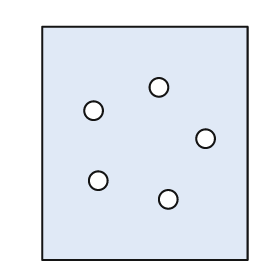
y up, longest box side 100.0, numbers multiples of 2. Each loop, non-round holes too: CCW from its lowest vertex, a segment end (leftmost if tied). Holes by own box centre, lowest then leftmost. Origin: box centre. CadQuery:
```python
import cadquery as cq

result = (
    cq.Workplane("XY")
    .moveTo(-44.0, -50.0)
    .lineTo(44.0, -50.0)
    .lineTo(44.0, 50.0)
    .lineTo(-44.0, 50.0)
    .close()
    .moveTo(10.0, -24.0)
    .circle(4.0)
    .moveTo(-20.0, -16.0)
    .circle(4.0)
    .moveTo(26.0, 2.0)
    .circle(4.0)
    .moveTo(-22.0, 14.0)
    .circle(4.0)
    .moveTo(6.0, 24.0)
    .circle(4.0)
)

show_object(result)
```